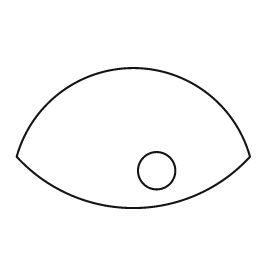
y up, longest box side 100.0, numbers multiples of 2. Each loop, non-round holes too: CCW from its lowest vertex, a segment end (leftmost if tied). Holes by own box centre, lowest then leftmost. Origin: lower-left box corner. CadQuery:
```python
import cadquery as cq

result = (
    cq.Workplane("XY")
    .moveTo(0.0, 22.0)
    .threePointArc((50.0, 0.0), (100.0, 22.0))
    .threePointArc((50.0, 60.0), (0.0, 22.0))
    .close()
    .moveTo(60.0, 16.0)
    .circle(8.0)
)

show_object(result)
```